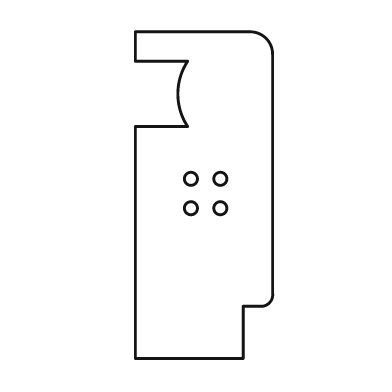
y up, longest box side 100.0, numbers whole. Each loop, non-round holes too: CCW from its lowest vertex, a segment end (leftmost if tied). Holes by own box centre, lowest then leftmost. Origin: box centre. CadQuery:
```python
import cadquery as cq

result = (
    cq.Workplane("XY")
    .moveTo(-21.0, -50.0)
    .lineTo(12.0, -50.0)
    .lineTo(12.0, -34.0)
    .lineTo(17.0, -34.0)
    .threePointArc((20.0, -33.0), (21.0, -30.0))
    .lineTo(21.0, 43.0)
    .threePointArc((19.0, 48.0), (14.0, 50.0))
    .lineTo(-21.0, 50.0)
    .lineTo(-21.0, 41.0)
    .lineTo(-5.0, 41.0)
    .threePointArc((-8.0, 31.0), (-5.0, 21.0))
    .lineTo(-21.0, 21.0)
    .close()
    .moveTo(-4.0, -4.0)
    .circle(2.0)
    .moveTo(5.0, -4.0)
    .circle(2.0)
    .moveTo(-4.0, 5.0)
    .circle(2.0)
    .moveTo(5.0, 5.0)
    .circle(2.0)
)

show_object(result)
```